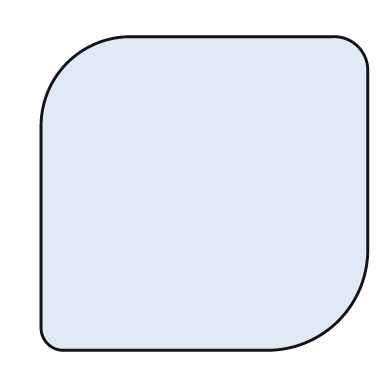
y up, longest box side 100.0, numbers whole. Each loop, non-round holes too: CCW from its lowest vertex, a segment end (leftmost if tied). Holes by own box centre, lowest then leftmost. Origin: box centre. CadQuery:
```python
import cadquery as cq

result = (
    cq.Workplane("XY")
    .moveTo(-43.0, -48.0)
    .lineTo(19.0, -48.0)
    .threePointArc((41.0, -39.0), (50.0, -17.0))
    .lineTo(50.0, 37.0)
    .threePointArc((47.0, 45.0), (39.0, 48.0))
    .lineTo(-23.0, 48.0)
    .threePointArc((-42.0, 40.0), (-50.0, 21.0))
    .lineTo(-50.0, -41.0)
    .threePointArc((-48.0, -46.0), (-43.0, -48.0))
    .close()
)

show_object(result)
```